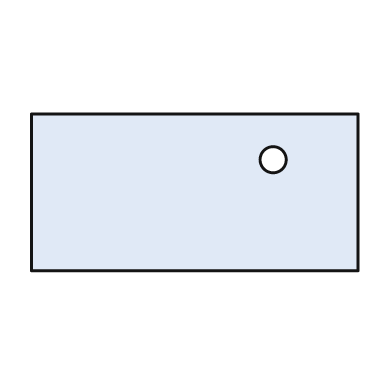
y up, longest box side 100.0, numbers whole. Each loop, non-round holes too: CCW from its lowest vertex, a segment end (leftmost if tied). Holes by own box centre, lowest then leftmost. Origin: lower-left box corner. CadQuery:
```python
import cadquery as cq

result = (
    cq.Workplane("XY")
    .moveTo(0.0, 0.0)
    .lineTo(100.0, 0.0)
    .lineTo(100.0, 48.0)
    .lineTo(0.0, 48.0)
    .close()
    .moveTo(74.0, 34.0)
    .circle(4.0)
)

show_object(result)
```